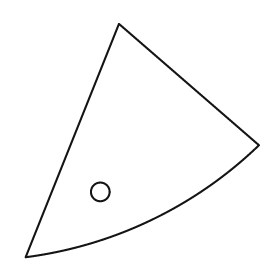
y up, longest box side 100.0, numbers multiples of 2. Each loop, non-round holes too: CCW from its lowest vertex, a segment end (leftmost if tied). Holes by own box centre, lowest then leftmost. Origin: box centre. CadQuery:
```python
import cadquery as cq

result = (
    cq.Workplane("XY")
    .moveTo(-50.0, -50.0)
    .threePointArc((4.0, -34.0), (50.0, -2.0))
    .lineTo(-10.0, 50.0)
    .close()
    .moveTo(-18.0, -22.0)
    .circle(4.0)
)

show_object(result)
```